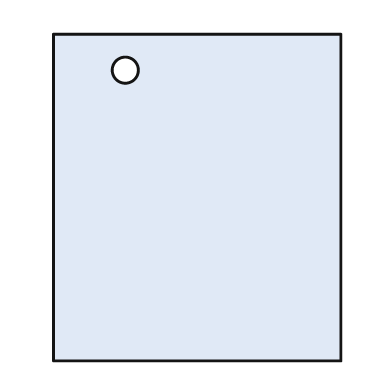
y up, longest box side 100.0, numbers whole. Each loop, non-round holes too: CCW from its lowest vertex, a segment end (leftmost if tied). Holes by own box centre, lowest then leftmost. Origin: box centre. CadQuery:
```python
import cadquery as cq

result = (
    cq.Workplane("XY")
    .moveTo(-44.0, -50.0)
    .lineTo(44.0, -50.0)
    .lineTo(44.0, 50.0)
    .lineTo(-44.0, 50.0)
    .close()
    .moveTo(-22.0, 39.0)
    .circle(4.0)
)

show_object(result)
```